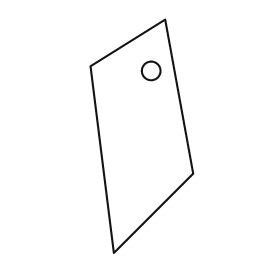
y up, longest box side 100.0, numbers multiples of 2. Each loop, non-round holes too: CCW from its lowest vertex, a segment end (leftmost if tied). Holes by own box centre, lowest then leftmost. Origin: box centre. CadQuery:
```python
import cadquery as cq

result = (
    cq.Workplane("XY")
    .moveTo(-12.0, -50.0)
    .lineTo(22.0, -16.0)
    .lineTo(10.0, 50.0)
    .lineTo(-22.0, 30.0)
    .close()
    .moveTo(4.0, 28.0)
    .circle(4.0)
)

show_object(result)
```